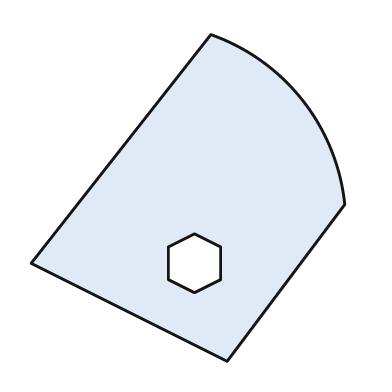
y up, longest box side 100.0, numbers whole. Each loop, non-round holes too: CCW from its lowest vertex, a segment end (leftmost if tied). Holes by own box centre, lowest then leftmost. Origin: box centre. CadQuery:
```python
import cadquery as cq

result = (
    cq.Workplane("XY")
    .moveTo(12.0, -50.0)
    .lineTo(48.0, -2.0)
    .threePointArc((35.0, 30.0), (7.0, 50.0))
    .lineTo(-48.0, -20.0)
    .close()
    .moveTo(2.0, -29.0)
    .lineTo(10.0, -25.0)
    .lineTo(10.0, -15.0)
    .lineTo(2.0, -11.0)
    .lineTo(-6.0, -15.0)
    .lineTo(-6.0, -25.0)
    .close()
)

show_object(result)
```